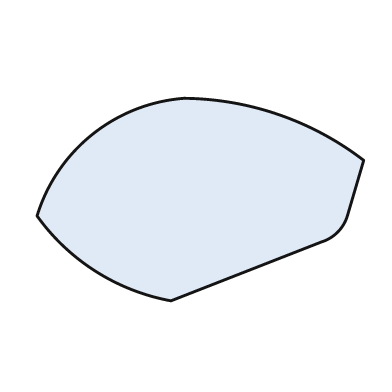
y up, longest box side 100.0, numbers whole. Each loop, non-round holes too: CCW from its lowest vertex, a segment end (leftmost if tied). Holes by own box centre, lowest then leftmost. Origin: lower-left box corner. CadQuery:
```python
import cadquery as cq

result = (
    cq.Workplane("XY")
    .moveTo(41.0, 0.0)
    .lineTo(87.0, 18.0)
    .threePointArc((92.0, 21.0), (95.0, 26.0))
    .lineTo(100.0, 43.0)
    .threePointArc((74.0, 57.0), (45.0, 62.0))
    .threePointArc((17.0, 51.0), (0.0, 26.0))
    .threePointArc((18.0, 9.0), (41.0, 0.0))
    .close()
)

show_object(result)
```